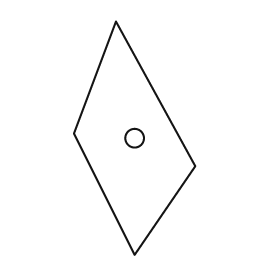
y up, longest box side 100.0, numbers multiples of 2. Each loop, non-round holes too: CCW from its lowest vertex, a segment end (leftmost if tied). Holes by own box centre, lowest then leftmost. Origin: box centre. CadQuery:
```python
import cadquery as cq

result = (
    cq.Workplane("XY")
    .moveTo(0.0, -50.0)
    .lineTo(26.0, -12.0)
    .lineTo(-8.0, 50.0)
    .lineTo(-26.0, 2.0)
    .close()
    .moveTo(0.0, 0.0)
    .circle(4.0)
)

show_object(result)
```